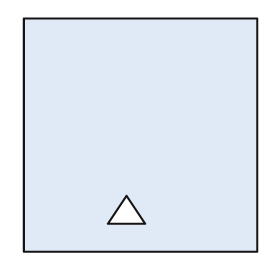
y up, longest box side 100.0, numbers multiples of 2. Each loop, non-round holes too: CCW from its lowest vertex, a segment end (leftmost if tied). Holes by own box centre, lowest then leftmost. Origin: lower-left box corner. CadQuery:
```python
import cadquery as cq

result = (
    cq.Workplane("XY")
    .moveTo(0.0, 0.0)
    .lineTo(100.0, 0.0)
    .lineTo(100.0, 100.0)
    .lineTo(0.0, 100.0)
    .close()
    .moveTo(36.0, 12.0)
    .lineTo(52.0, 12.0)
    .lineTo(44.0, 24.0)
    .close()
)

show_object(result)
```